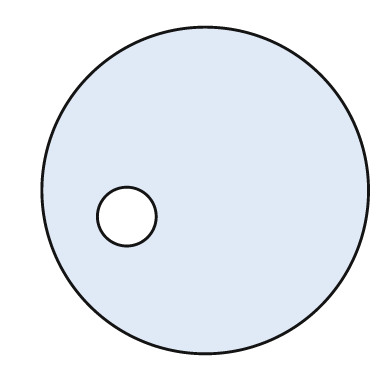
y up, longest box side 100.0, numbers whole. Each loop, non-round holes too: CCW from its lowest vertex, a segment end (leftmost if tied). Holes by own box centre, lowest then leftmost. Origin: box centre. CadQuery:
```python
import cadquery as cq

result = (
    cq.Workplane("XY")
    .moveTo(0.0, 0.0)
    .circle(50.0)
    .moveTo(-24.0, -8.0)
    .circle(9.0)
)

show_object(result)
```